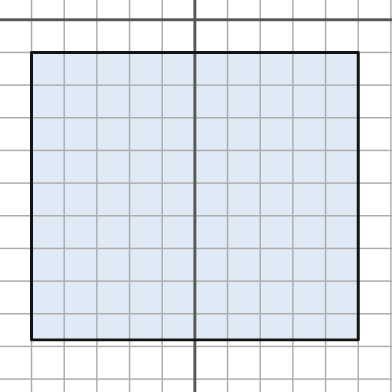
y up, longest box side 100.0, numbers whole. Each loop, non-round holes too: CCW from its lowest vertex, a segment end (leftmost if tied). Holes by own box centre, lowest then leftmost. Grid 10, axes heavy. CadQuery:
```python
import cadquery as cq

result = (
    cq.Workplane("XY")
    .moveTo(-50.0, -98.0)
    .lineTo(50.0, -98.0)
    .lineTo(50.0, -10.0)
    .lineTo(-50.0, -10.0)
    .close()
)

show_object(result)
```